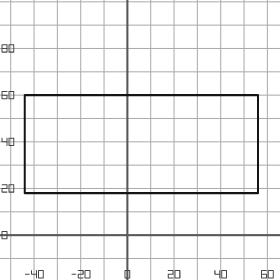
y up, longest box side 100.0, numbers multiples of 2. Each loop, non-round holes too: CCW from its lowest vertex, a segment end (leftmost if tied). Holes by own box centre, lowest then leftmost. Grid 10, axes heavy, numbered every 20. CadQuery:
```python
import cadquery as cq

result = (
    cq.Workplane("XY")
    .moveTo(-44.0, 18.0)
    .lineTo(56.0, 18.0)
    .lineTo(56.0, 60.0)
    .lineTo(-44.0, 60.0)
    .close()
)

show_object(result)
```